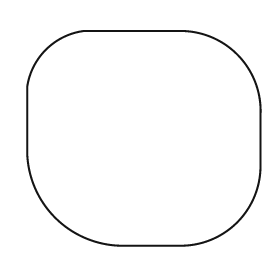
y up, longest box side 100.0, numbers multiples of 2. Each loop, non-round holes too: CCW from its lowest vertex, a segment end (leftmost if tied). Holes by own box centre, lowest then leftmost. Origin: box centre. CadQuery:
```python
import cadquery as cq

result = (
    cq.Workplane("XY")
    .moveTo(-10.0, -46.0)
    .lineTo(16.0, -46.0)
    .threePointArc((40.0, -36.0), (50.0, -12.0))
    .lineTo(50.0, 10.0)
    .threePointArc((40.0, 36.0), (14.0, 46.0))
    .lineTo(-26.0, 46.0)
    .threePointArc((-42.0, 38.0), (-50.0, 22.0))
    .lineTo(-50.0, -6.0)
    .threePointArc((-38.0, -34.0), (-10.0, -46.0))
    .close()
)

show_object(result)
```